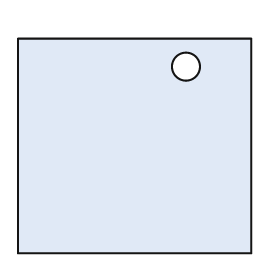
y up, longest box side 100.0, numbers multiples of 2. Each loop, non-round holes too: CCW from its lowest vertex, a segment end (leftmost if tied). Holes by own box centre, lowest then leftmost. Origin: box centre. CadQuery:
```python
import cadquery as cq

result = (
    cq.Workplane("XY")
    .moveTo(-50.0, -46.0)
    .lineTo(50.0, -46.0)
    .lineTo(50.0, 46.0)
    .lineTo(-50.0, 46.0)
    .close()
    .moveTo(22.0, 34.0)
    .circle(6.0)
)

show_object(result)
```